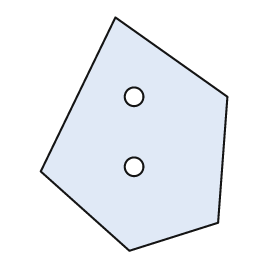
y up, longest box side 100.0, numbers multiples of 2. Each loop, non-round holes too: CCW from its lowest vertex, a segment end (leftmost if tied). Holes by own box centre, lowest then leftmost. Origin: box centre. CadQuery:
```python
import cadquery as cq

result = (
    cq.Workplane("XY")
    .moveTo(-2.0, -50.0)
    .lineTo(36.0, -38.0)
    .lineTo(40.0, 16.0)
    .lineTo(-8.0, 50.0)
    .lineTo(-40.0, -16.0)
    .close()
    .moveTo(0.0, -14.0)
    .circle(4.0)
    .moveTo(0.0, 16.0)
    .circle(4.0)
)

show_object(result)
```